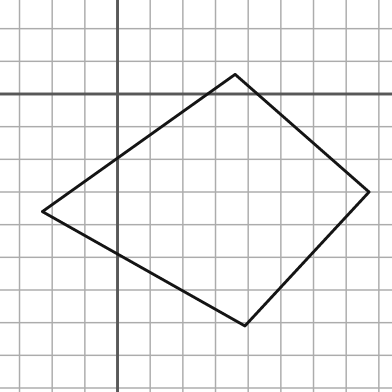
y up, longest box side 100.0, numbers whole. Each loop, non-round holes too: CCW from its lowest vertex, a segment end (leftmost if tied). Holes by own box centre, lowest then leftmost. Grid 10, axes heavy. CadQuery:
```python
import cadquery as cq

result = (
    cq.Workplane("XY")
    .moveTo(39.0, -71.0)
    .lineTo(77.0, -30.0)
    .lineTo(36.0, 6.0)
    .lineTo(-23.0, -36.0)
    .close()
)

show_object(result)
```